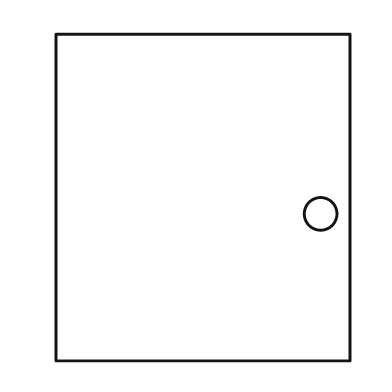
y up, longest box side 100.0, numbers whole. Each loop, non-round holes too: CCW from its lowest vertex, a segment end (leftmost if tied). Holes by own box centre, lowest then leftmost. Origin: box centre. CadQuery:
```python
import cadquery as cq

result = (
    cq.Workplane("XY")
    .moveTo(-45.0, -50.0)
    .lineTo(45.0, -50.0)
    .lineTo(45.0, 50.0)
    .lineTo(-45.0, 50.0)
    .close()
    .moveTo(36.0, -5.0)
    .circle(5.0)
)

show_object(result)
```